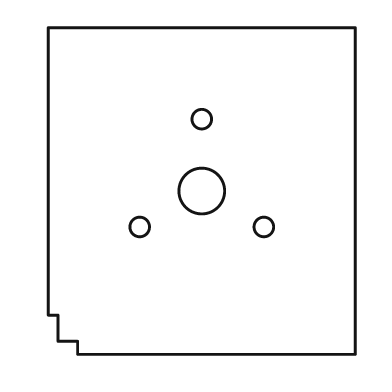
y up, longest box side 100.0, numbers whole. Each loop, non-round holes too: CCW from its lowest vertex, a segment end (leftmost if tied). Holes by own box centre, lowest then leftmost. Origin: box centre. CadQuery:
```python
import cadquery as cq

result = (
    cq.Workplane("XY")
    .moveTo(-38.0, -50.0)
    .lineTo(47.0, -50.0)
    .lineTo(47.0, 50.0)
    .lineTo(-47.0, 50.0)
    .lineTo(-47.0, -38.0)
    .lineTo(-44.0, -38.0)
    .lineTo(-44.0, -46.0)
    .lineTo(-38.0, -46.0)
    .close()
    .moveTo(-19.0, -11.0)
    .circle(3.0)
    .moveTo(19.0, -11.0)
    .circle(3.0)
    .moveTo(0.0, 0.0)
    .circle(7.0)
    .moveTo(0.0, 22.0)
    .circle(3.0)
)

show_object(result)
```